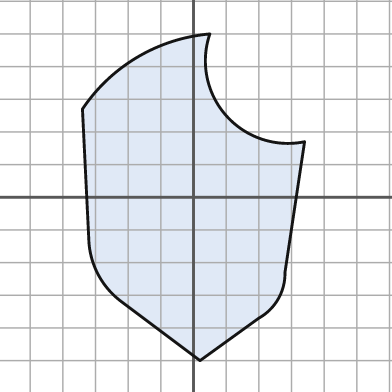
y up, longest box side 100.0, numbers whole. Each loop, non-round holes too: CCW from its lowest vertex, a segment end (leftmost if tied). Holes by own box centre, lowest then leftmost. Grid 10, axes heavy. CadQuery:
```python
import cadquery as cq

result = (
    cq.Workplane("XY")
    .moveTo(2.0, -50.0)
    .lineTo(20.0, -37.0)
    .threePointArc((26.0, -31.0), (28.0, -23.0))
    .lineTo(34.0, 17.0)
    .threePointArc((10.0, 25.0), (5.0, 50.0))
    .threePointArc((-17.0, 43.0), (-34.0, 27.0))
    .lineTo(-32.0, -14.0)
    .threePointArc((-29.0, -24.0), (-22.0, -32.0))
    .close()
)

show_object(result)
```